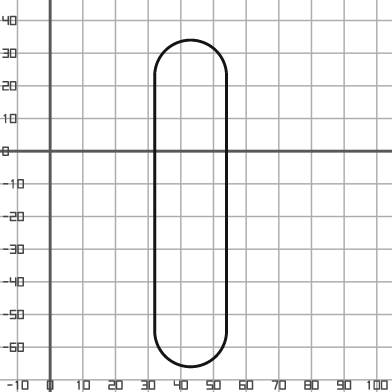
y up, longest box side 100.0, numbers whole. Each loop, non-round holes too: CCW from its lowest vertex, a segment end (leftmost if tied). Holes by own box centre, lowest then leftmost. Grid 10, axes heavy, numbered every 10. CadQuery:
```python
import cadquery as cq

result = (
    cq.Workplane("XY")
    .moveTo(32.0, -55.0)
    .threePointArc((43.0, -66.0), (54.0, -55.0))
    .lineTo(54.0, 23.0)
    .threePointArc((43.0, 34.0), (32.0, 23.0))
    .close()
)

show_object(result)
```